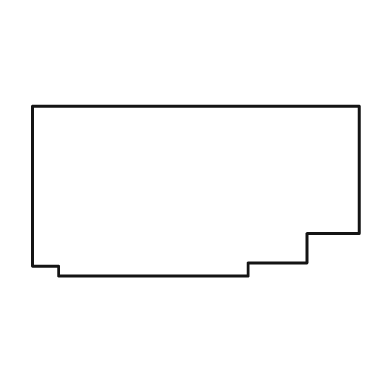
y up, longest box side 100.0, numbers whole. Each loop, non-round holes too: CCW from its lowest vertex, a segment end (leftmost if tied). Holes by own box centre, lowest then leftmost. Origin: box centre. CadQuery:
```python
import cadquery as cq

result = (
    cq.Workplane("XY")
    .moveTo(-42.0, -26.0)
    .lineTo(16.0, -26.0)
    .lineTo(16.0, -22.0)
    .lineTo(34.0, -22.0)
    .lineTo(34.0, -13.0)
    .lineTo(50.0, -13.0)
    .lineTo(50.0, 26.0)
    .lineTo(-50.0, 26.0)
    .lineTo(-50.0, -23.0)
    .lineTo(-42.0, -23.0)
    .close()
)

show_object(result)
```